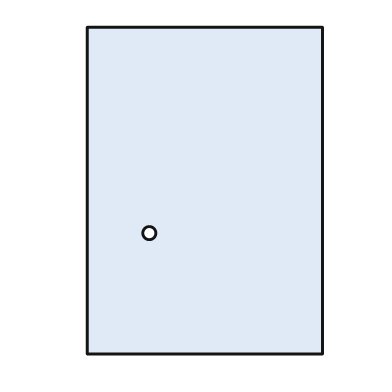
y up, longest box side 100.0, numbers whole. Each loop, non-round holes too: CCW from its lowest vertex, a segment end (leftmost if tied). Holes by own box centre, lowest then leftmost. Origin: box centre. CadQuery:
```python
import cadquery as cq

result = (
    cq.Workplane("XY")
    .moveTo(-36.0, -50.0)
    .lineTo(36.0, -50.0)
    .lineTo(36.0, 50.0)
    .lineTo(-36.0, 50.0)
    .close()
    .moveTo(-17.0, -13.0)
    .circle(2.0)
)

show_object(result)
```